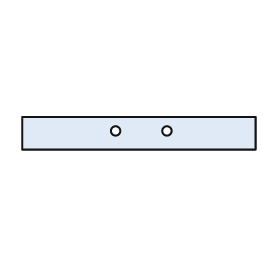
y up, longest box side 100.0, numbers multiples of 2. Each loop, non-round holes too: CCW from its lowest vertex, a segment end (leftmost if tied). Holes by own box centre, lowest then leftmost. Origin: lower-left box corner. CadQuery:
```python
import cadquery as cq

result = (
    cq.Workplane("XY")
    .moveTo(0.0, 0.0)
    .lineTo(100.0, 0.0)
    .lineTo(100.0, 14.0)
    .lineTo(0.0, 14.0)
    .close()
    .moveTo(40.0, 8.0)
    .circle(2.0)
    .moveTo(62.0, 8.0)
    .circle(2.0)
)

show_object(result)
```